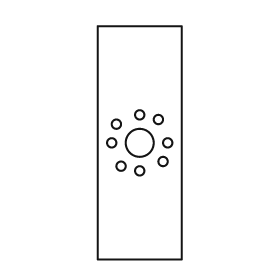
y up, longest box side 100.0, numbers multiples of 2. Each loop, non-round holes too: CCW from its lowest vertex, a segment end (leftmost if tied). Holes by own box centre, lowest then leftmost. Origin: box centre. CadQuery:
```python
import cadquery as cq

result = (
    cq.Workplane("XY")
    .moveTo(-18.0, -50.0)
    .lineTo(18.0, -50.0)
    .lineTo(18.0, 50.0)
    .lineTo(-18.0, 50.0)
    .close()
    .moveTo(0.0, -12.0)
    .circle(2.0)
    .moveTo(-8.0, -10.0)
    .circle(2.0)
    .moveTo(10.0, -8.0)
    .circle(2.0)
    .moveTo(-12.0, 0.0)
    .circle(2.0)
    .moveTo(0.0, 0.0)
    .circle(6.0)
    .moveTo(12.0, 0.0)
    .circle(2.0)
    .moveTo(-10.0, 8.0)
    .circle(2.0)
    .moveTo(8.0, 10.0)
    .circle(2.0)
    .moveTo(0.0, 12.0)
    .circle(2.0)
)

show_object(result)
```